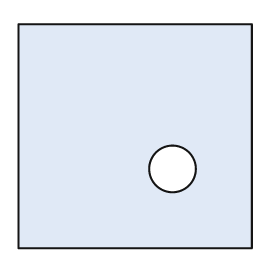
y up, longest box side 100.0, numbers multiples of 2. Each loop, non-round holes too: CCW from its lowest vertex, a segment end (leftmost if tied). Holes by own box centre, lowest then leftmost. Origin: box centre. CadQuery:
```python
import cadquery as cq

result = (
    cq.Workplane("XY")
    .moveTo(-50.0, -48.0)
    .lineTo(50.0, -48.0)
    .lineTo(50.0, 48.0)
    .lineTo(-50.0, 48.0)
    .close()
    .moveTo(16.0, -14.0)
    .circle(10.0)
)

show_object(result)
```